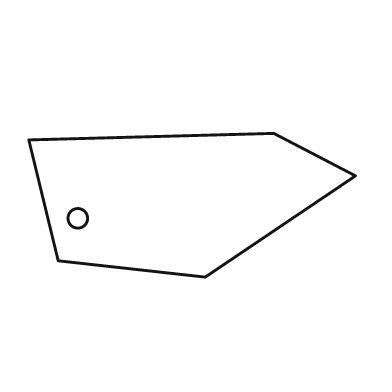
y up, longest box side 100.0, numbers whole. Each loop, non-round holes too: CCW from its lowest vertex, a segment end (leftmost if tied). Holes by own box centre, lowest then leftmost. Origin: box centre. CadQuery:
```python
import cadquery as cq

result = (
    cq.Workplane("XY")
    .moveTo(4.0, -22.0)
    .lineTo(50.0, 9.0)
    .lineTo(25.0, 22.0)
    .lineTo(-50.0, 20.0)
    .lineTo(-41.0, -17.0)
    .close()
    .moveTo(-35.0, -4.0)
    .circle(3.0)
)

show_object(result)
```